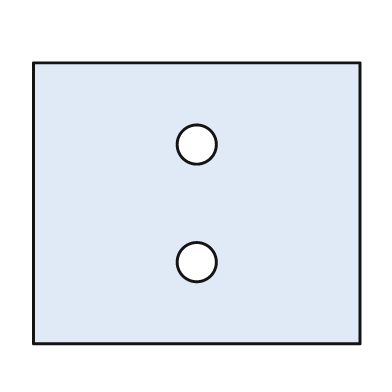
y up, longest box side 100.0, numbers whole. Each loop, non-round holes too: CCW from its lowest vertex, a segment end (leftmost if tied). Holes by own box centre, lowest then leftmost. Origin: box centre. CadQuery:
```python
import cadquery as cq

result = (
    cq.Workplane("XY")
    .moveTo(-50.0, -43.0)
    .lineTo(50.0, -43.0)
    .lineTo(50.0, 43.0)
    .lineTo(-50.0, 43.0)
    .close()
    .moveTo(0.0, -18.0)
    .circle(6.0)
    .moveTo(0.0, 18.0)
    .circle(6.0)
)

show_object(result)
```